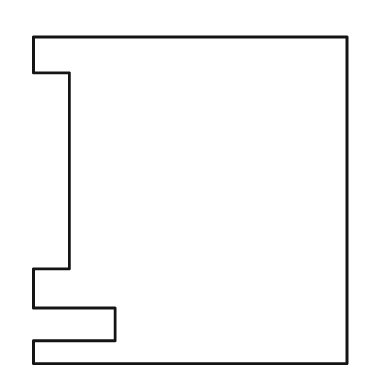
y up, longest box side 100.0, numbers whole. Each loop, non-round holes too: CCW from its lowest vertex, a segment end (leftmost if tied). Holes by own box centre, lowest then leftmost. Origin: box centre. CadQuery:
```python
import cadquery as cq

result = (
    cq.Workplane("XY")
    .moveTo(-48.0, -50.0)
    .lineTo(48.0, -50.0)
    .lineTo(48.0, 50.0)
    .lineTo(-48.0, 50.0)
    .lineTo(-48.0, 39.0)
    .lineTo(-37.0, 39.0)
    .lineTo(-37.0, -21.0)
    .lineTo(-48.0, -21.0)
    .lineTo(-48.0, -33.0)
    .lineTo(-23.0, -33.0)
    .lineTo(-23.0, -43.0)
    .lineTo(-48.0, -43.0)
    .close()
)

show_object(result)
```